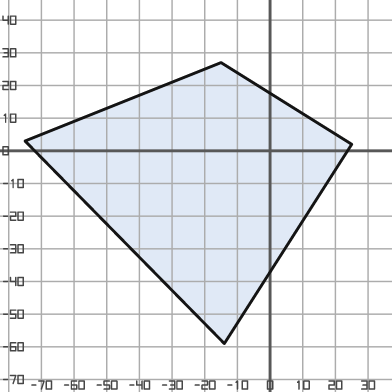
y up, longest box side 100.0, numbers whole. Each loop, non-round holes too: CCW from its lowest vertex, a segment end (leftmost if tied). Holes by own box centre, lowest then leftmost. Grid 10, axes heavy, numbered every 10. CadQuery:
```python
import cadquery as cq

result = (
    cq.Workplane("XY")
    .moveTo(-14.0, -59.0)
    .lineTo(25.0, 2.0)
    .lineTo(-15.0, 27.0)
    .lineTo(-75.0, 3.0)
    .close()
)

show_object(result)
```